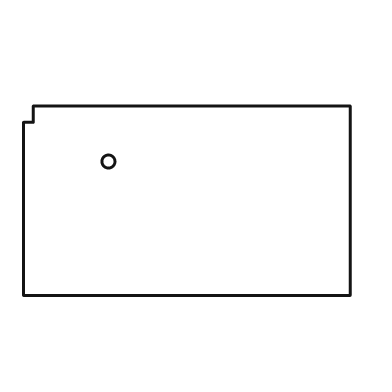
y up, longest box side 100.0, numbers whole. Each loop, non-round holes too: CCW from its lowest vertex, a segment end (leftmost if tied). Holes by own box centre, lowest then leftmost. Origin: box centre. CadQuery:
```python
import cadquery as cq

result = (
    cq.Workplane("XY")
    .moveTo(-50.0, -29.0)
    .lineTo(50.0, -29.0)
    .lineTo(50.0, 29.0)
    .lineTo(-47.0, 29.0)
    .lineTo(-47.0, 24.0)
    .lineTo(-50.0, 24.0)
    .close()
    .moveTo(-24.0, 12.0)
    .circle(2.0)
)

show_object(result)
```